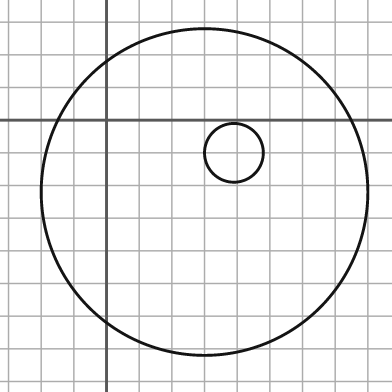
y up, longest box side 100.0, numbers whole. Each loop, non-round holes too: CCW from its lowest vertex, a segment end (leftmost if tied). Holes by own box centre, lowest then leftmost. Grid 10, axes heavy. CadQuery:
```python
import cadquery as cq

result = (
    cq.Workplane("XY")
    .moveTo(30.0, -22.0)
    .circle(50.0)
    .moveTo(39.0, -10.0)
    .circle(9.0)
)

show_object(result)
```